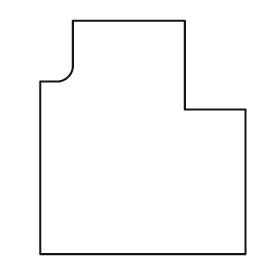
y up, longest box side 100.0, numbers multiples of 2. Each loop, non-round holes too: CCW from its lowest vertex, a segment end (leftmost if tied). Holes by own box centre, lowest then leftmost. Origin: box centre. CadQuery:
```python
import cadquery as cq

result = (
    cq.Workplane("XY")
    .moveTo(-44.0, -50.0)
    .lineTo(44.0, -50.0)
    .lineTo(44.0, 12.0)
    .lineTo(18.0, 12.0)
    .lineTo(18.0, 50.0)
    .lineTo(-30.0, 50.0)
    .lineTo(-30.0, 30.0)
    .threePointArc((-32.0, 26.0), (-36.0, 24.0))
    .lineTo(-44.0, 24.0)
    .close()
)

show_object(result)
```